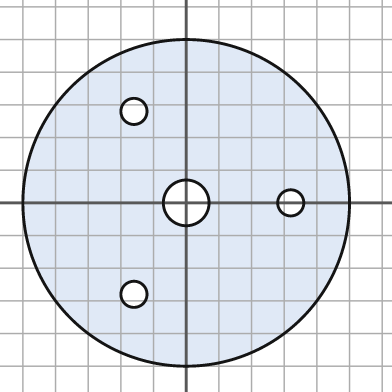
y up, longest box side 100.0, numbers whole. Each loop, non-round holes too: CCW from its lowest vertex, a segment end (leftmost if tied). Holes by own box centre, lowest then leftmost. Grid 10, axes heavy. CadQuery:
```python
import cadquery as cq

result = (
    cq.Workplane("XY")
    .moveTo(0.0, 0.0)
    .circle(50.0)
    .moveTo(-16.0, -28.0)
    .circle(4.0)
    .moveTo(0.0, 0.0)
    .circle(7.0)
    .moveTo(32.0, 0.0)
    .circle(4.0)
    .moveTo(-16.0, 28.0)
    .circle(4.0)
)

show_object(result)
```